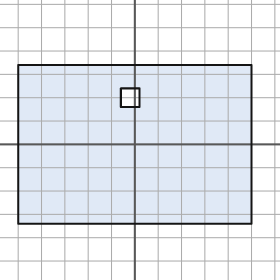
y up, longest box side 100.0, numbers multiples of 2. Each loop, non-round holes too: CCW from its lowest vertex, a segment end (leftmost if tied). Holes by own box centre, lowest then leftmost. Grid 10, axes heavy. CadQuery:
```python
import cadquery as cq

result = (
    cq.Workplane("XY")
    .moveTo(-50.0, -34.0)
    .lineTo(50.0, -34.0)
    .lineTo(50.0, 34.0)
    .lineTo(-50.0, 34.0)
    .close()
    .moveTo(-6.0, 16.0)
    .lineTo(2.0, 16.0)
    .lineTo(2.0, 24.0)
    .lineTo(-6.0, 24.0)
    .close()
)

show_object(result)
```